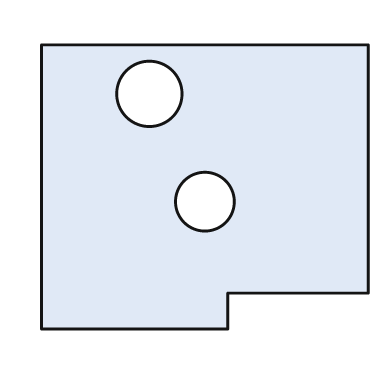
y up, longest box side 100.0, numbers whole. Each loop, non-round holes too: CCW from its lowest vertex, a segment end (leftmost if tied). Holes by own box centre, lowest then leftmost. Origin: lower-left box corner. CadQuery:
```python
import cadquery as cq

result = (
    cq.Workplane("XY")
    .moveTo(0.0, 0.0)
    .lineTo(57.0, 0.0)
    .lineTo(57.0, 11.0)
    .lineTo(100.0, 11.0)
    .lineTo(100.0, 87.0)
    .lineTo(0.0, 87.0)
    .close()
    .moveTo(50.0, 39.0)
    .circle(9.0)
    .moveTo(33.0, 72.0)
    .circle(10.0)
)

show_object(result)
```